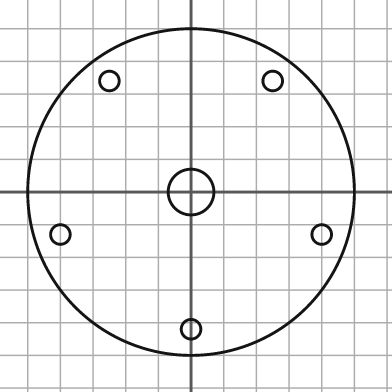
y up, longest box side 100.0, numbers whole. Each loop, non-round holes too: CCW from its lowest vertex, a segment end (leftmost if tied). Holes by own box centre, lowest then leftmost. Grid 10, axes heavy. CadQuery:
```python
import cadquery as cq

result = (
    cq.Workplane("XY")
    .moveTo(0.0, 0.0)
    .circle(50.0)
    .moveTo(0.0, -42.0)
    .circle(3.0)
    .moveTo(-40.0, -13.0)
    .circle(3.0)
    .moveTo(40.0, -13.0)
    .circle(3.0)
    .moveTo(0.0, 0.0)
    .circle(7.0)
    .moveTo(-25.0, 34.0)
    .circle(3.0)
    .moveTo(25.0, 34.0)
    .circle(3.0)
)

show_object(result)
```